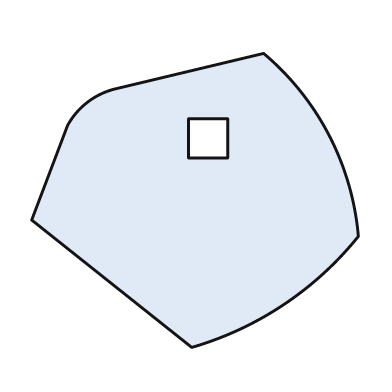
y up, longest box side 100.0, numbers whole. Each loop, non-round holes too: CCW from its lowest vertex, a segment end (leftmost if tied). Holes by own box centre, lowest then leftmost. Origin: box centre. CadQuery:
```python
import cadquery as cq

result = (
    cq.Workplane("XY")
    .moveTo(-1.0, -45.0)
    .threePointArc((27.0, -32.0), (50.0, -11.0))
    .threePointArc((41.0, 20.0), (21.0, 45.0))
    .lineTo(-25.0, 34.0)
    .threePointArc((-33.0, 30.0), (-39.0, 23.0))
    .lineTo(-50.0, -6.0)
    .close()
    .moveTo(-2.0, 13.0)
    .lineTo(10.0, 13.0)
    .lineTo(10.0, 25.0)
    .lineTo(-2.0, 25.0)
    .close()
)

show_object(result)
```